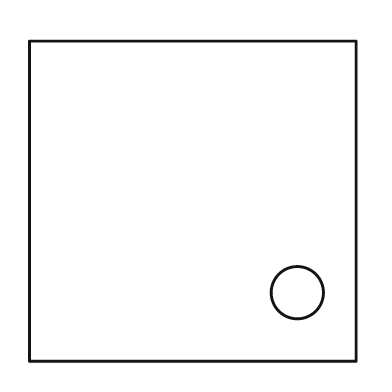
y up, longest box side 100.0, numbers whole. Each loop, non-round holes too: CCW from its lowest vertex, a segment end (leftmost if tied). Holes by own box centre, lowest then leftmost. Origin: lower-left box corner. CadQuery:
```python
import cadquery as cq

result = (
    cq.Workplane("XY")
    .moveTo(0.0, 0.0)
    .lineTo(100.0, 0.0)
    .lineTo(100.0, 98.0)
    .lineTo(0.0, 98.0)
    .close()
    .moveTo(82.0, 21.0)
    .circle(8.0)
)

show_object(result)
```